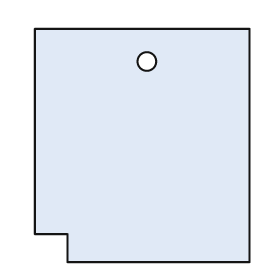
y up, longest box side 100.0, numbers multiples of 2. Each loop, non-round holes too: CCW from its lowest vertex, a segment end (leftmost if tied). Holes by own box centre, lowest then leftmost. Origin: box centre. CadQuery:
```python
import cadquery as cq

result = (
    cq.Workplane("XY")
    .moveTo(-32.0, -50.0)
    .lineTo(46.0, -50.0)
    .lineTo(46.0, 50.0)
    .lineTo(-46.0, 50.0)
    .lineTo(-46.0, -38.0)
    .lineTo(-32.0, -38.0)
    .close()
    .moveTo(2.0, 36.0)
    .circle(4.0)
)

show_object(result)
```